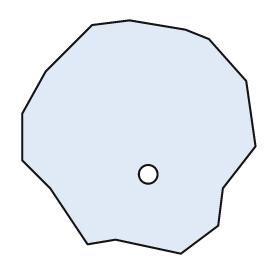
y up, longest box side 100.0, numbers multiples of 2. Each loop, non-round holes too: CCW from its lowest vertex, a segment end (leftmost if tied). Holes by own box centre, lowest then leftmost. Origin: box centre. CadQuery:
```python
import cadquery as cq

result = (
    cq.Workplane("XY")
    .moveTo(18.0, -50.0)
    .lineTo(34.0, -38.0)
    .lineTo(36.0, -22.0)
    .lineTo(50.0, -4.0)
    .lineTo(46.0, 24.0)
    .lineTo(30.0, 42.0)
    .lineTo(20.0, 46.0)
    .lineTo(-4.0, 50.0)
    .lineTo(-20.0, 48.0)
    .lineTo(-40.0, 28.0)
    .lineTo(-50.0, 10.0)
    .lineTo(-50.0, -10.0)
    .lineTo(-38.0, -22.0)
    .lineTo(-22.0, -46.0)
    .lineTo(-10.0, -44.0)
    .close()
    .moveTo(4.0, -16.0)
    .circle(4.0)
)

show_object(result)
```